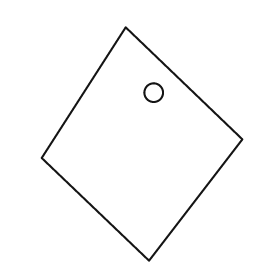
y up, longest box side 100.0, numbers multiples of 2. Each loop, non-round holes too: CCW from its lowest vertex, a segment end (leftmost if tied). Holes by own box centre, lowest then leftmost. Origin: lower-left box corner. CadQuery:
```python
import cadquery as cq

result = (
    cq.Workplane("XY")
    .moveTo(46.0, 0.0)
    .lineTo(86.0, 52.0)
    .lineTo(36.0, 100.0)
    .lineTo(0.0, 44.0)
    .close()
    .moveTo(48.0, 72.0)
    .circle(4.0)
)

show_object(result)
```